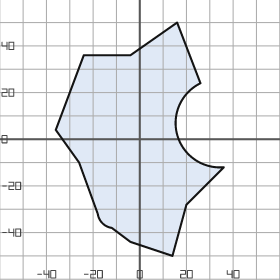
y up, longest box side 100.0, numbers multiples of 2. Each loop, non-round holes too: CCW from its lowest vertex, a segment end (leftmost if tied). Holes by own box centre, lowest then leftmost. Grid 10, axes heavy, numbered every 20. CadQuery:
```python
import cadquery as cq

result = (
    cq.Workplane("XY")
    .moveTo(14.0, -50.0)
    .lineTo(20.0, -28.0)
    .lineTo(36.0, -12.0)
    .threePointArc((16.0, 2.0), (26.0, 24.0))
    .lineTo(16.0, 50.0)
    .lineTo(-4.0, 36.0)
    .lineTo(-24.0, 36.0)
    .lineTo(-36.0, 4.0)
    .lineTo(-26.0, -10.0)
    .lineTo(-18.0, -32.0)
    .threePointArc((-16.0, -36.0), (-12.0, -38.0))
    .lineTo(-4.0, -44.0)
    .close()
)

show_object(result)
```